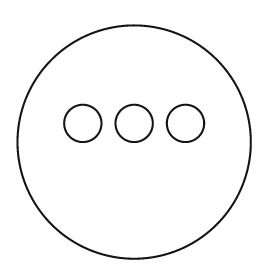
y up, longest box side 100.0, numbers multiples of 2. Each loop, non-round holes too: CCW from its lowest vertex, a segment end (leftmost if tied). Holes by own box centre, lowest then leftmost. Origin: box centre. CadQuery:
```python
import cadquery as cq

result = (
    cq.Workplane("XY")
    .moveTo(0.0, 0.0)
    .circle(50.0)
    .moveTo(-22.0, 8.0)
    .circle(8.0)
    .moveTo(0.0, 8.0)
    .circle(8.0)
    .moveTo(22.0, 8.0)
    .circle(8.0)
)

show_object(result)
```